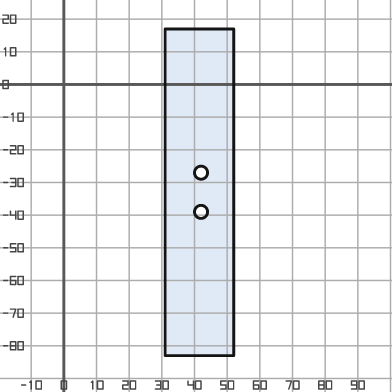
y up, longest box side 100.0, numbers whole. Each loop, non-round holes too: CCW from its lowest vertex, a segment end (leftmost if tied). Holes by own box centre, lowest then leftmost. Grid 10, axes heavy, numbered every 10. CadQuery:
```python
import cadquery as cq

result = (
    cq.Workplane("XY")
    .moveTo(31.0, -83.0)
    .lineTo(52.0, -83.0)
    .lineTo(52.0, 17.0)
    .lineTo(31.0, 17.0)
    .close()
    .moveTo(42.0, -39.0)
    .circle(2.0)
    .moveTo(42.0, -27.0)
    .circle(2.0)
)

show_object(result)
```